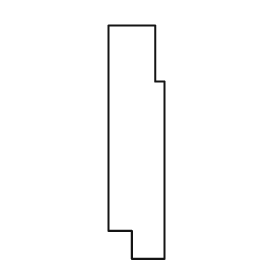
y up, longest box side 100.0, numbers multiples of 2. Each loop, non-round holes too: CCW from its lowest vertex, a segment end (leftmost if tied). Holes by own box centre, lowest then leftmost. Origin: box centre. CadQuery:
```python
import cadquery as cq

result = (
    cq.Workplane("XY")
    .moveTo(-2.0, -50.0)
    .lineTo(12.0, -50.0)
    .lineTo(12.0, 26.0)
    .lineTo(8.0, 26.0)
    .lineTo(8.0, 50.0)
    .lineTo(-12.0, 50.0)
    .lineTo(-12.0, -38.0)
    .lineTo(-2.0, -38.0)
    .close()
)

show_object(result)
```